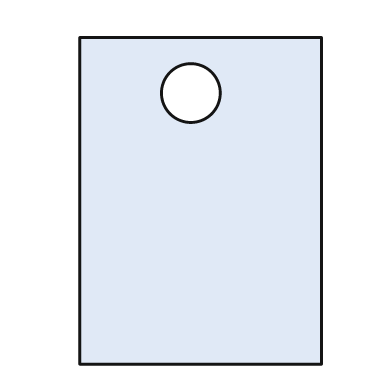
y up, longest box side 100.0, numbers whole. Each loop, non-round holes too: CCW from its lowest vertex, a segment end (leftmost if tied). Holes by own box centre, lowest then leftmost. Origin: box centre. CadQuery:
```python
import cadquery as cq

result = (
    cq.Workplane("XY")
    .moveTo(-37.0, -50.0)
    .lineTo(37.0, -50.0)
    .lineTo(37.0, 50.0)
    .lineTo(-37.0, 50.0)
    .close()
    .moveTo(-3.0, 33.0)
    .circle(9.0)
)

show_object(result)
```